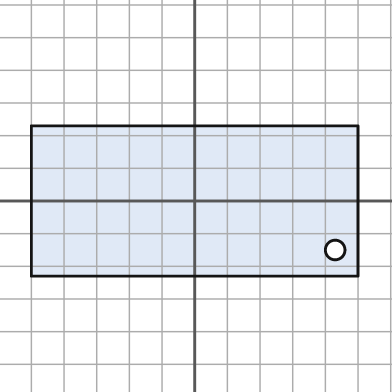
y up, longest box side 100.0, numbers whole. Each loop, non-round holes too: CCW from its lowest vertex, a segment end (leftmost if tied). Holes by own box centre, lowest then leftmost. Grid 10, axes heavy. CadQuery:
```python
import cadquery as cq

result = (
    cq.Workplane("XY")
    .moveTo(-50.0, -23.0)
    .lineTo(50.0, -23.0)
    .lineTo(50.0, 23.0)
    .lineTo(-50.0, 23.0)
    .close()
    .moveTo(43.0, -15.0)
    .circle(3.0)
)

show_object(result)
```